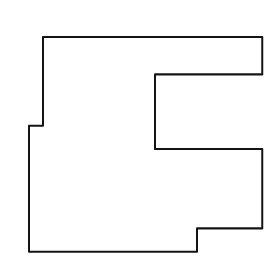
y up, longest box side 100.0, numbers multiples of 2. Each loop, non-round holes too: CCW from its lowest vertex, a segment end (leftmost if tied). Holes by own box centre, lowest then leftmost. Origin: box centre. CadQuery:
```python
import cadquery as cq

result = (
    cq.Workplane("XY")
    .moveTo(-50.0, -46.0)
    .lineTo(22.0, -46.0)
    .lineTo(22.0, -36.0)
    .lineTo(50.0, -36.0)
    .lineTo(50.0, -2.0)
    .lineTo(4.0, -2.0)
    .lineTo(4.0, 30.0)
    .lineTo(50.0, 30.0)
    .lineTo(50.0, 46.0)
    .lineTo(-44.0, 46.0)
    .lineTo(-44.0, 8.0)
    .lineTo(-50.0, 8.0)
    .close()
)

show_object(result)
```